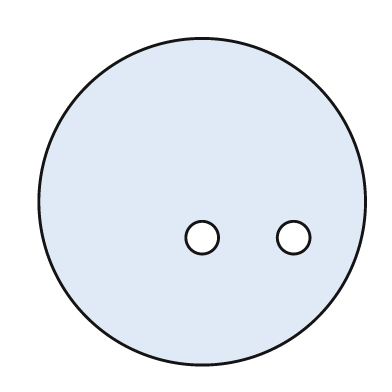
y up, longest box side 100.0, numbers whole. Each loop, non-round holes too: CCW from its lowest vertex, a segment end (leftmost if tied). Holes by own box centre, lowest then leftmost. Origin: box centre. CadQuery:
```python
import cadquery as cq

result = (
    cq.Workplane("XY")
    .moveTo(0.0, 0.0)
    .circle(50.0)
    .moveTo(0.0, -11.0)
    .circle(5.0)
    .moveTo(28.0, -11.0)
    .circle(5.0)
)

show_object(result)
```